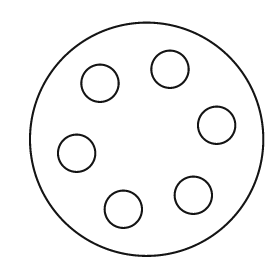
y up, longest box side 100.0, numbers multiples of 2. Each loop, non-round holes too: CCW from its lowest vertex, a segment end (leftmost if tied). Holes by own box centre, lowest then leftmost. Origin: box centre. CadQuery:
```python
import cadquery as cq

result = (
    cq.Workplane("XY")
    .moveTo(0.0, 0.0)
    .circle(50.0)
    .moveTo(-10.0, -30.0)
    .circle(8.0)
    .moveTo(20.0, -24.0)
    .circle(8.0)
    .moveTo(-30.0, -6.0)
    .circle(8.0)
    .moveTo(30.0, 6.0)
    .circle(8.0)
    .moveTo(-20.0, 24.0)
    .circle(8.0)
    .moveTo(10.0, 30.0)
    .circle(8.0)
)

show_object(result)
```